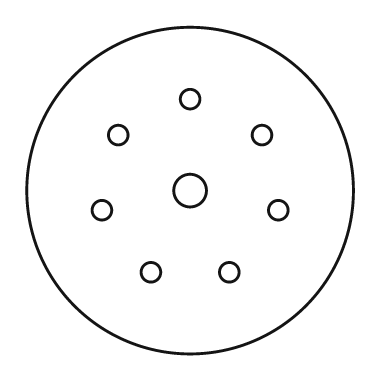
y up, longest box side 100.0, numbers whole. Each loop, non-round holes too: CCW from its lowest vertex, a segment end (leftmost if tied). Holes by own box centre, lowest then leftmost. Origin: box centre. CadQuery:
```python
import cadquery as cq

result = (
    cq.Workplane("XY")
    .moveTo(0.0, 0.0)
    .circle(50.0)
    .moveTo(-12.0, -25.0)
    .circle(3.0)
    .moveTo(12.0, -25.0)
    .circle(3.0)
    .moveTo(-27.0, -6.0)
    .circle(3.0)
    .moveTo(27.0, -6.0)
    .circle(3.0)
    .moveTo(0.0, 0.0)
    .circle(5.0)
    .moveTo(-22.0, 17.0)
    .circle(3.0)
    .moveTo(22.0, 17.0)
    .circle(3.0)
    .moveTo(0.0, 28.0)
    .circle(3.0)
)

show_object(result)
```